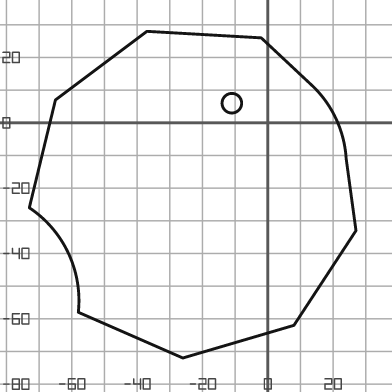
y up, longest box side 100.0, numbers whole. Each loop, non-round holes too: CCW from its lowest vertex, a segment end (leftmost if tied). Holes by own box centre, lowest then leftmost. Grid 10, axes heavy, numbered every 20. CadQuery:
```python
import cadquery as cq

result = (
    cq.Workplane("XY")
    .moveTo(-26.0, -72.0)
    .lineTo(8.0, -62.0)
    .lineTo(27.0, -33.0)
    .lineTo(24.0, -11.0)
    .threePointArc((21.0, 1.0), (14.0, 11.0))
    .lineTo(-2.0, 26.0)
    .lineTo(-37.0, 28.0)
    .lineTo(-65.0, 7.0)
    .lineTo(-73.0, -26.0)
    .threePointArc((-61.0, -40.0), (-58.0, -58.0))
    .close()
    .moveTo(-11.0, 6.0)
    .circle(3.0)
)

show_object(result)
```